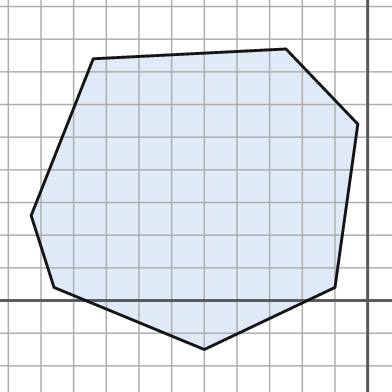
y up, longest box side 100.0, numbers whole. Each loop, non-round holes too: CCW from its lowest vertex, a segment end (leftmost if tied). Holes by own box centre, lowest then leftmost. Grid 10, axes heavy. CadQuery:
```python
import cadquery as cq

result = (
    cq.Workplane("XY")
    .moveTo(-50.0, -15.0)
    .lineTo(-10.0, 4.0)
    .lineTo(-3.0, 54.0)
    .lineTo(-25.0, 77.0)
    .lineTo(-84.0, 74.0)
    .lineTo(-103.0, 26.0)
    .lineTo(-96.0, 4.0)
    .close()
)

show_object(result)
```